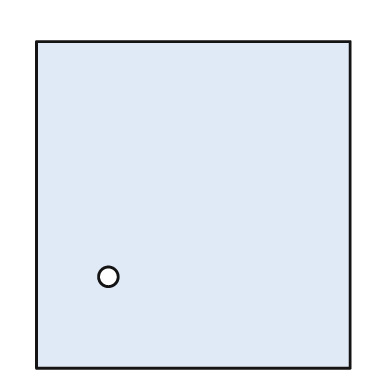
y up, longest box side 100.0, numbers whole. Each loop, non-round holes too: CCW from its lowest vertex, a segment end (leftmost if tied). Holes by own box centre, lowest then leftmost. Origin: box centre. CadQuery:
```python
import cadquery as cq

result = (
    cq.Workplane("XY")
    .moveTo(-48.0, -50.0)
    .lineTo(48.0, -50.0)
    .lineTo(48.0, 50.0)
    .lineTo(-48.0, 50.0)
    .close()
    .moveTo(-26.0, -22.0)
    .circle(3.0)
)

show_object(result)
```